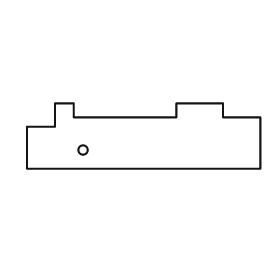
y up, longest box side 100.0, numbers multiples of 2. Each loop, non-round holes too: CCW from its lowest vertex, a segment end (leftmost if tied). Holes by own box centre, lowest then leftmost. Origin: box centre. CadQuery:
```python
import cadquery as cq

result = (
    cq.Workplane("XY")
    .moveTo(-50.0, -14.0)
    .lineTo(50.0, -14.0)
    .lineTo(50.0, 8.0)
    .lineTo(34.0, 8.0)
    .lineTo(34.0, 14.0)
    .lineTo(14.0, 14.0)
    .lineTo(14.0, 8.0)
    .lineTo(-30.0, 8.0)
    .lineTo(-30.0, 14.0)
    .lineTo(-38.0, 14.0)
    .lineTo(-38.0, 4.0)
    .lineTo(-50.0, 4.0)
    .close()
    .moveTo(-26.0, -6.0)
    .circle(2.0)
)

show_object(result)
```